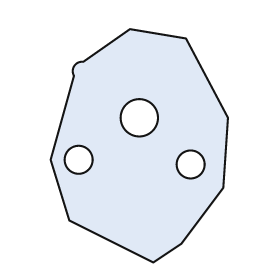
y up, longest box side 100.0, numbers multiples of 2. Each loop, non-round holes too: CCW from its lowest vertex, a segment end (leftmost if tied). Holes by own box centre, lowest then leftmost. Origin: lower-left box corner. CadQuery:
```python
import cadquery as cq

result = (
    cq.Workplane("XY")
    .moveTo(44.0, 0.0)
    .lineTo(56.0, 8.0)
    .lineTo(74.0, 32.0)
    .lineTo(76.0, 62.0)
    .lineTo(58.0, 96.0)
    .lineTo(34.0, 100.0)
    .lineTo(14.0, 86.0)
    .threePointArc((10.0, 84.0), (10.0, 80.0))
    .lineTo(0.0, 44.0)
    .lineTo(8.0, 18.0)
    .close()
    .moveTo(60.0, 42.0)
    .circle(6.0)
    .moveTo(12.0, 44.0)
    .circle(6.0)
    .moveTo(38.0, 62.0)
    .circle(8.0)
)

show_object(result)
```